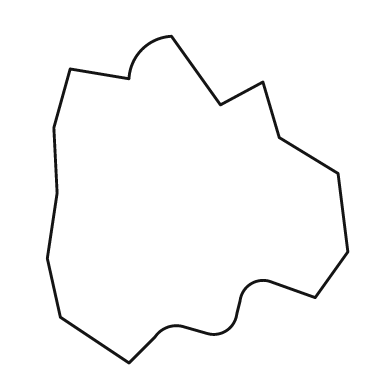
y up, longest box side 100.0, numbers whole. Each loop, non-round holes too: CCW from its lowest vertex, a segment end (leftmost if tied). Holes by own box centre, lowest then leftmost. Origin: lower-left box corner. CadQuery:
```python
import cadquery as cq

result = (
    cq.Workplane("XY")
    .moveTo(25.0, 0.0)
    .lineTo(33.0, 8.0)
    .threePointArc((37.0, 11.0), (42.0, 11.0))
    .lineTo(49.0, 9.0)
    .threePointArc((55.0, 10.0), (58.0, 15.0))
    .lineTo(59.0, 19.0)
    .threePointArc((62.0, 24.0), (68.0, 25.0))
    .lineTo(82.0, 20.0)
    .lineTo(92.0, 34.0)
    .lineTo(89.0, 58.0)
    .lineTo(71.0, 69.0)
    .lineTo(66.0, 86.0)
    .lineTo(53.0, 79.0)
    .lineTo(38.0, 100.0)
    .threePointArc((29.0, 96.0), (25.0, 87.0))
    .lineTo(7.0, 90.0)
    .lineTo(2.0, 72.0)
    .lineTo(3.0, 52.0)
    .lineTo(0.0, 32.0)
    .lineTo(4.0, 14.0)
    .close()
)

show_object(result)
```